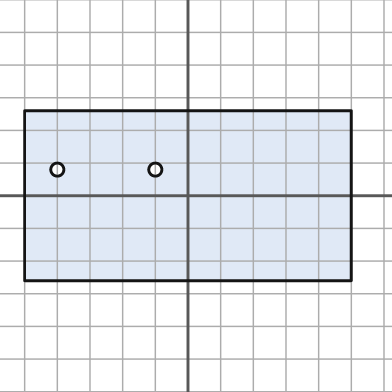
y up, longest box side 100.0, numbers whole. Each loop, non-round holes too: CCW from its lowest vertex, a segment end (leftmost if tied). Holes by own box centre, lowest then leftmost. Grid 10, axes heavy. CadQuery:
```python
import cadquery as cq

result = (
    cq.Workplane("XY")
    .moveTo(-50.0, -26.0)
    .lineTo(50.0, -26.0)
    .lineTo(50.0, 26.0)
    .lineTo(-50.0, 26.0)
    .close()
    .moveTo(-40.0, 8.0)
    .circle(2.0)
    .moveTo(-10.0, 8.0)
    .circle(2.0)
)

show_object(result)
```